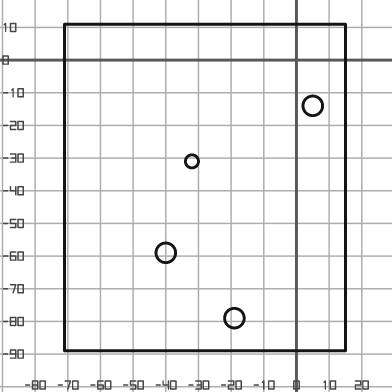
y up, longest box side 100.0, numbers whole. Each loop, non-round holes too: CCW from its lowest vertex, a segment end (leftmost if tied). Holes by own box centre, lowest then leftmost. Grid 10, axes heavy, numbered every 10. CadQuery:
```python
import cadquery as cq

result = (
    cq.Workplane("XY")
    .moveTo(-71.0, -89.0)
    .lineTo(15.0, -89.0)
    .lineTo(15.0, 11.0)
    .lineTo(-71.0, 11.0)
    .close()
    .moveTo(-19.0, -79.0)
    .circle(3.0)
    .moveTo(-40.0, -59.0)
    .circle(3.0)
    .moveTo(-32.0, -31.0)
    .circle(2.0)
    .moveTo(5.0, -14.0)
    .circle(3.0)
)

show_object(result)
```